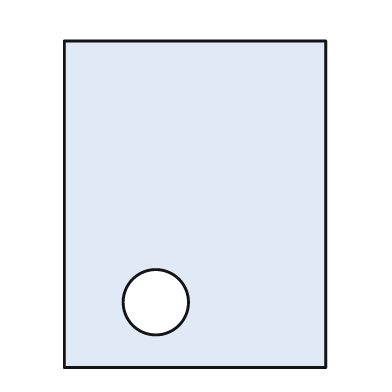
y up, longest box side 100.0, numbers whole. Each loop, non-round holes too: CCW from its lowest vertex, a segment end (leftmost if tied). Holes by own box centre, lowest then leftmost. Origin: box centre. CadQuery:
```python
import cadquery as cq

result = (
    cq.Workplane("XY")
    .moveTo(-40.0, -50.0)
    .lineTo(40.0, -50.0)
    .lineTo(40.0, 50.0)
    .lineTo(-40.0, 50.0)
    .close()
    .moveTo(-12.0, -30.0)
    .circle(10.0)
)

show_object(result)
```